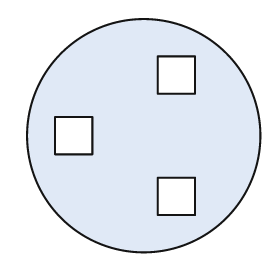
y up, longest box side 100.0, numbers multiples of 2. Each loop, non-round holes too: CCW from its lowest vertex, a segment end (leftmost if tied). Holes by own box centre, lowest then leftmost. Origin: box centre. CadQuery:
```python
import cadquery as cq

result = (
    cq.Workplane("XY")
    .moveTo(0.0, 0.0)
    .circle(50.0)
    .moveTo(6.0, -34.0)
    .lineTo(22.0, -34.0)
    .lineTo(22.0, -18.0)
    .lineTo(6.0, -18.0)
    .close()
    .moveTo(-38.0, -8.0)
    .lineTo(-22.0, -8.0)
    .lineTo(-22.0, 8.0)
    .lineTo(-38.0, 8.0)
    .close()
    .moveTo(6.0, 18.0)
    .lineTo(22.0, 18.0)
    .lineTo(22.0, 34.0)
    .lineTo(6.0, 34.0)
    .close()
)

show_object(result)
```